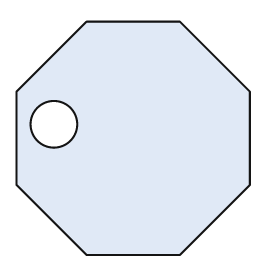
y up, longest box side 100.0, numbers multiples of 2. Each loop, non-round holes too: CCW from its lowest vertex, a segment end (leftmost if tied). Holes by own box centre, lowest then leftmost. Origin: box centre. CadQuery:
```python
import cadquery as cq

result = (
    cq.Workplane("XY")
    .moveTo(-20.0, -50.0)
    .lineTo(20.0, -50.0)
    .lineTo(50.0, -20.0)
    .lineTo(50.0, 20.0)
    .lineTo(20.0, 50.0)
    .lineTo(-20.0, 50.0)
    .lineTo(-50.0, 20.0)
    .lineTo(-50.0, -20.0)
    .close()
    .moveTo(-34.0, 6.0)
    .circle(10.0)
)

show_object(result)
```